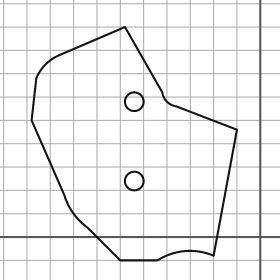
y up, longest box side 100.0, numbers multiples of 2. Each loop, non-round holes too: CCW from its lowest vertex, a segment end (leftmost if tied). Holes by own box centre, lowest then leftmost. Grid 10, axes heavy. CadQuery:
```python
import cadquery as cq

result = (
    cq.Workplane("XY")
    .moveTo(-60.0, -10.0)
    .lineTo(-44.0, -10.0)
    .threePointArc((-32.0, -6.0), (-20.0, -8.0))
    .lineTo(-10.0, 46.0)
    .lineTo(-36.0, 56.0)
    .threePointArc((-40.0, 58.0), (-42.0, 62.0))
    .lineTo(-58.0, 90.0)
    .lineTo(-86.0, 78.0)
    .threePointArc((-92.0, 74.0), (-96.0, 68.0))
    .lineTo(-98.0, 50.0)
    .lineTo(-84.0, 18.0)
    .threePointArc((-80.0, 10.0), (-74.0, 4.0))
    .close()
    .moveTo(-54.0, 24.0)
    .circle(4.0)
    .moveTo(-54.0, 58.0)
    .circle(4.0)
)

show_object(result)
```